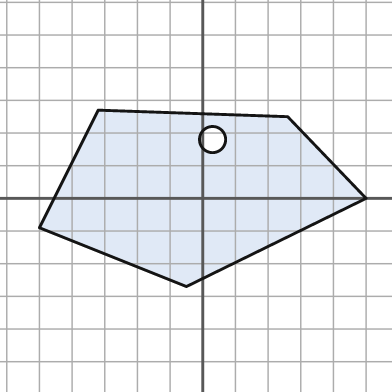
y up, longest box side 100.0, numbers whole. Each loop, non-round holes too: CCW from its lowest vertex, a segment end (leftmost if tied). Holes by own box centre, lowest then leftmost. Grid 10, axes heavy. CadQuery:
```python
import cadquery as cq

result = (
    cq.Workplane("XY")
    .moveTo(-5.0, -27.0)
    .lineTo(50.0, 0.0)
    .lineTo(26.0, 25.0)
    .lineTo(-32.0, 27.0)
    .lineTo(-50.0, -9.0)
    .close()
    .moveTo(3.0, 18.0)
    .circle(4.0)
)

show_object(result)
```